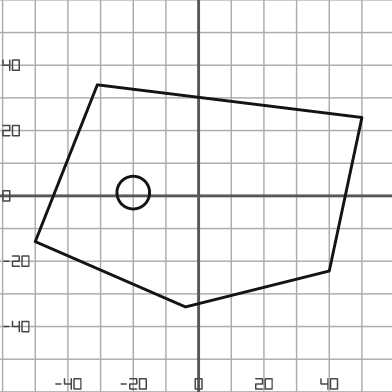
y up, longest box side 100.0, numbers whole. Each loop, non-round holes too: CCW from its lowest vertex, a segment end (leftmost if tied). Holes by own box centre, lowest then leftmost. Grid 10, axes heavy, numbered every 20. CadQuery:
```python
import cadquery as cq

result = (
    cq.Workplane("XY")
    .moveTo(-4.0, -34.0)
    .lineTo(40.0, -23.0)
    .lineTo(50.0, 24.0)
    .lineTo(-31.0, 34.0)
    .lineTo(-50.0, -14.0)
    .close()
    .moveTo(-20.0, 1.0)
    .circle(5.0)
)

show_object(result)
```